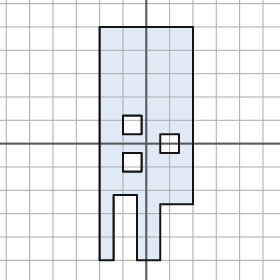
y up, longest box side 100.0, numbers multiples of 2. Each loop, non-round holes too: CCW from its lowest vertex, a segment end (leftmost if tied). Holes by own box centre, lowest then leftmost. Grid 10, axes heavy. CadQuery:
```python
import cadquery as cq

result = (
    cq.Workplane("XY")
    .moveTo(-20.0, -50.0)
    .lineTo(-14.0, -50.0)
    .lineTo(-14.0, -22.0)
    .lineTo(-4.0, -22.0)
    .lineTo(-4.0, -50.0)
    .lineTo(6.0, -50.0)
    .lineTo(6.0, -26.0)
    .lineTo(20.0, -26.0)
    .lineTo(20.0, 50.0)
    .lineTo(-20.0, 50.0)
    .close()
    .moveTo(-10.0, -12.0)
    .lineTo(-2.0, -12.0)
    .lineTo(-2.0, -4.0)
    .lineTo(-10.0, -4.0)
    .close()
    .moveTo(6.0, -4.0)
    .lineTo(14.0, -4.0)
    .lineTo(14.0, 4.0)
    .lineTo(6.0, 4.0)
    .close()
    .moveTo(-10.0, 4.0)
    .lineTo(-2.0, 4.0)
    .lineTo(-2.0, 12.0)
    .lineTo(-10.0, 12.0)
    .close()
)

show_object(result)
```